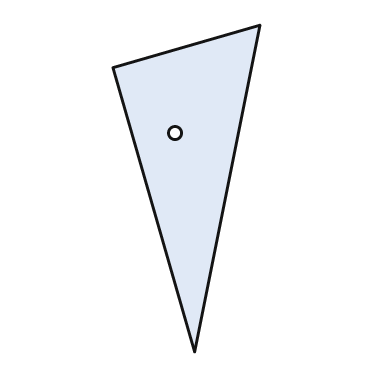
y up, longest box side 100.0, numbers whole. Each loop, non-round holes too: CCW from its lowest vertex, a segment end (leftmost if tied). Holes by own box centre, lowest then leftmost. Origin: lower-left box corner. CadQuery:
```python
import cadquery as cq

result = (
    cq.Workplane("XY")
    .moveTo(25.0, 0.0)
    .lineTo(45.0, 100.0)
    .lineTo(0.0, 87.0)
    .close()
    .moveTo(19.0, 67.0)
    .circle(2.0)
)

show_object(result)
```